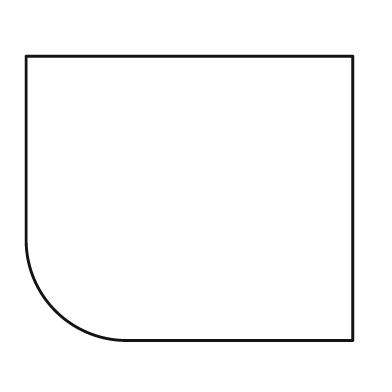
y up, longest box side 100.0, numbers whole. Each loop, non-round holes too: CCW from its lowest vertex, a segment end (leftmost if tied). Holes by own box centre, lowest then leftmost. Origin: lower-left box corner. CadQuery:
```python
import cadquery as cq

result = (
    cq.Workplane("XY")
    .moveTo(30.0, 0.0)
    .lineTo(100.0, 0.0)
    .lineTo(100.0, 87.0)
    .lineTo(0.0, 87.0)
    .lineTo(0.0, 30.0)
    .threePointArc((9.0, 9.0), (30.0, 0.0))
    .close()
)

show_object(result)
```